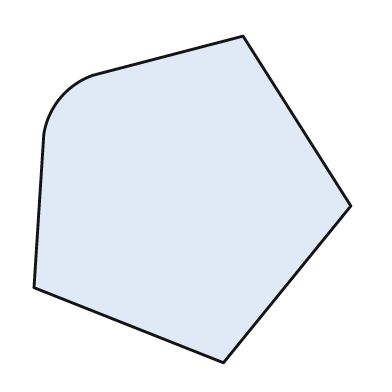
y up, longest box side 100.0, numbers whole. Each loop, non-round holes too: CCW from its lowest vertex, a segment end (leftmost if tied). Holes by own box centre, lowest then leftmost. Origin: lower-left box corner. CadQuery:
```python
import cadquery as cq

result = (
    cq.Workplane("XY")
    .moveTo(58.0, 0.0)
    .lineTo(97.0, 48.0)
    .lineTo(64.0, 100.0)
    .lineTo(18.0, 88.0)
    .threePointArc((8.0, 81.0), (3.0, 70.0))
    .lineTo(0.0, 23.0)
    .close()
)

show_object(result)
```